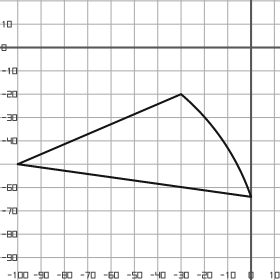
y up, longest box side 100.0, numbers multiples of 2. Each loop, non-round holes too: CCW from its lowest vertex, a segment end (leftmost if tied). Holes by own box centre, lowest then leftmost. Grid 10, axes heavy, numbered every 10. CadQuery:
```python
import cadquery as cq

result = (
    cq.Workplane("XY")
    .moveTo(0.0, -64.0)
    .threePointArc((-12.0, -40.0), (-30.0, -20.0))
    .lineTo(-100.0, -50.0)
    .close()
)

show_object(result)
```